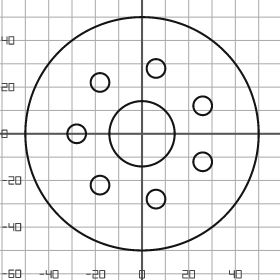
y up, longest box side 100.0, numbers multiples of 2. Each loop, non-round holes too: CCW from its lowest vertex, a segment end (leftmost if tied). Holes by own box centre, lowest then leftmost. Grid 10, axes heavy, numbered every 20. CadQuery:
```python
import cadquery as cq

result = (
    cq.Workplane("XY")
    .moveTo(0.0, 0.0)
    .circle(50.0)
    .moveTo(6.0, -28.0)
    .circle(4.0)
    .moveTo(-18.0, -22.0)
    .circle(4.0)
    .moveTo(26.0, -12.0)
    .circle(4.0)
    .moveTo(-28.0, 0.0)
    .circle(4.0)
    .moveTo(0.0, 0.0)
    .circle(14.0)
    .moveTo(26.0, 12.0)
    .circle(4.0)
    .moveTo(-18.0, 22.0)
    .circle(4.0)
    .moveTo(6.0, 28.0)
    .circle(4.0)
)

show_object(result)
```